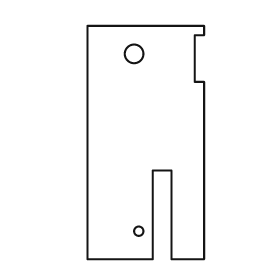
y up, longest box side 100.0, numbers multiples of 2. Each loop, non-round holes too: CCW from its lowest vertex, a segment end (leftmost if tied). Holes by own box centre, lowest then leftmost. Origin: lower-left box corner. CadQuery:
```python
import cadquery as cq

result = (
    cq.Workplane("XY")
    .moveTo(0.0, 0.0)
    .lineTo(28.0, 0.0)
    .lineTo(28.0, 38.0)
    .lineTo(36.0, 38.0)
    .lineTo(36.0, 0.0)
    .lineTo(50.0, 0.0)
    .lineTo(50.0, 76.0)
    .lineTo(46.0, 76.0)
    .lineTo(46.0, 96.0)
    .lineTo(50.0, 96.0)
    .lineTo(50.0, 100.0)
    .lineTo(0.0, 100.0)
    .close()
    .moveTo(22.0, 12.0)
    .circle(2.0)
    .moveTo(20.0, 88.0)
    .circle(4.0)
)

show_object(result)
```